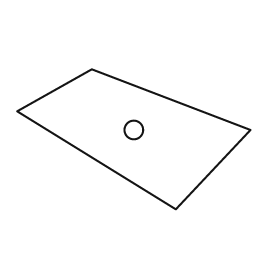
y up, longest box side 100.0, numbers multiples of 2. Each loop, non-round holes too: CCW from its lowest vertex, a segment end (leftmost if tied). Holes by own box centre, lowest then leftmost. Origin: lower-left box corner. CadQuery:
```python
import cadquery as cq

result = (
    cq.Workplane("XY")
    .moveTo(68.0, 0.0)
    .lineTo(100.0, 34.0)
    .lineTo(32.0, 60.0)
    .lineTo(0.0, 42.0)
    .close()
    .moveTo(50.0, 34.0)
    .circle(4.0)
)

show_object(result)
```